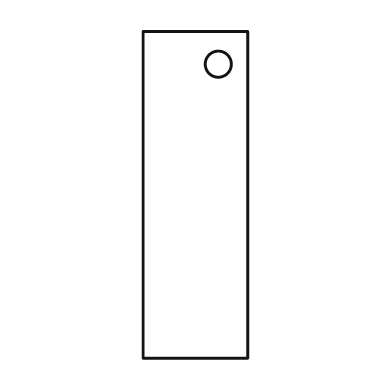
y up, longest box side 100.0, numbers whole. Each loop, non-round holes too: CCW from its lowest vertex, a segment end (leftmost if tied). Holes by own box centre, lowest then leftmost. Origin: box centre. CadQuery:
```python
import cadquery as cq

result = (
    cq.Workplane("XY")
    .moveTo(-16.0, -50.0)
    .lineTo(16.0, -50.0)
    .lineTo(16.0, 50.0)
    .lineTo(-16.0, 50.0)
    .close()
    .moveTo(7.0, 40.0)
    .circle(4.0)
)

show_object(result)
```